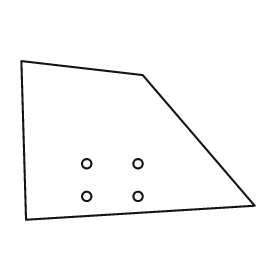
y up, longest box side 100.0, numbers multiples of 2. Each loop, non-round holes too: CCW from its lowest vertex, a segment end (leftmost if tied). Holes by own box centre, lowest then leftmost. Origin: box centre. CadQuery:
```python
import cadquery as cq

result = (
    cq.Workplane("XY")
    .moveTo(-48.0, -34.0)
    .lineTo(50.0, -28.0)
    .lineTo(2.0, 28.0)
    .lineTo(-50.0, 34.0)
    .close()
    .moveTo(-22.0, -24.0)
    .circle(2.0)
    .moveTo(0.0, -24.0)
    .circle(2.0)
    .moveTo(-22.0, -10.0)
    .circle(2.0)
    .moveTo(0.0, -10.0)
    .circle(2.0)
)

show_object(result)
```